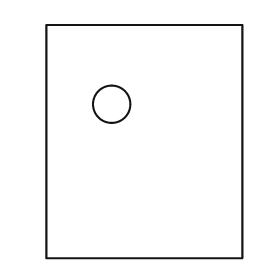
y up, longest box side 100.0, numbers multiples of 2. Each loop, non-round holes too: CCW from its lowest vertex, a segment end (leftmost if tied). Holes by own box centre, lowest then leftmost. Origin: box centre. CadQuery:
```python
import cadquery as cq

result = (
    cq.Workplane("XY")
    .moveTo(-42.0, -50.0)
    .lineTo(42.0, -50.0)
    .lineTo(42.0, 50.0)
    .lineTo(-42.0, 50.0)
    .close()
    .moveTo(-14.0, 16.0)
    .circle(8.0)
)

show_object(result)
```